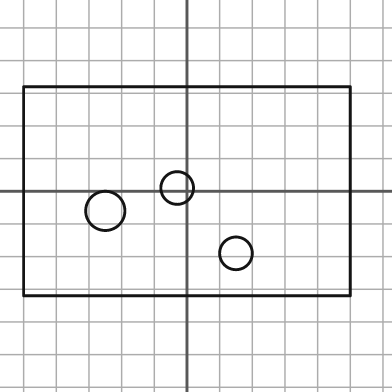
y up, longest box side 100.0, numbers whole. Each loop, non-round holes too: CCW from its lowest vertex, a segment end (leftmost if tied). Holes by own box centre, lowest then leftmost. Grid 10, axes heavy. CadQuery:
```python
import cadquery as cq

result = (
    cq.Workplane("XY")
    .moveTo(-50.0, -32.0)
    .lineTo(50.0, -32.0)
    .lineTo(50.0, 32.0)
    .lineTo(-50.0, 32.0)
    .close()
    .moveTo(15.0, -19.0)
    .circle(5.0)
    .moveTo(-25.0, -6.0)
    .circle(6.0)
    .moveTo(-3.0, 1.0)
    .circle(5.0)
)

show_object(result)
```